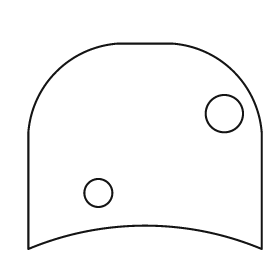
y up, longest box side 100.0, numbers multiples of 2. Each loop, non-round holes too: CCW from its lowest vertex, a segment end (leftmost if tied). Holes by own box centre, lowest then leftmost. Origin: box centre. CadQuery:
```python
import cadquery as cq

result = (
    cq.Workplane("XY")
    .moveTo(-50.0, -44.0)
    .threePointArc((0.0, -34.0), (50.0, -44.0))
    .lineTo(50.0, 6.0)
    .threePointArc((38.0, 32.0), (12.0, 44.0))
    .lineTo(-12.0, 44.0)
    .threePointArc((-38.0, 32.0), (-50.0, 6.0))
    .close()
    .moveTo(-20.0, -20.0)
    .circle(6.0)
    .moveTo(34.0, 14.0)
    .circle(8.0)
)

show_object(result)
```